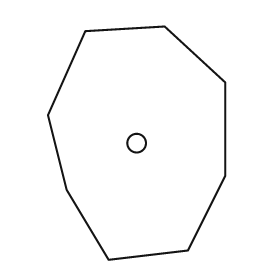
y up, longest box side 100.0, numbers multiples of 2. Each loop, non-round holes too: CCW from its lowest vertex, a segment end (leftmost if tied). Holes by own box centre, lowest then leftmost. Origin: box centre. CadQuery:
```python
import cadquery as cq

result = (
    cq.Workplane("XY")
    .moveTo(-12.0, -50.0)
    .lineTo(22.0, -46.0)
    .lineTo(38.0, -14.0)
    .lineTo(38.0, 26.0)
    .lineTo(12.0, 50.0)
    .lineTo(-22.0, 48.0)
    .lineTo(-38.0, 12.0)
    .lineTo(-30.0, -20.0)
    .close()
    .moveTo(0.0, 0.0)
    .circle(4.0)
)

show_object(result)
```